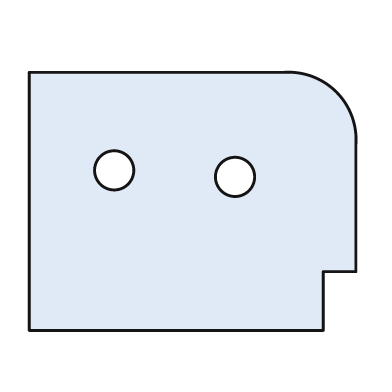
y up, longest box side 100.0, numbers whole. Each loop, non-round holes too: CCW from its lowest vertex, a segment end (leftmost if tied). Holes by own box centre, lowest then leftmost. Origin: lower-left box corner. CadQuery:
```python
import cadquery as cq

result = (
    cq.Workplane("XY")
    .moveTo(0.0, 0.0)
    .lineTo(90.0, 0.0)
    .lineTo(90.0, 18.0)
    .lineTo(100.0, 18.0)
    .lineTo(100.0, 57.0)
    .threePointArc((94.0, 73.0), (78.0, 79.0))
    .lineTo(0.0, 79.0)
    .close()
    .moveTo(63.0, 47.0)
    .circle(6.0)
    .moveTo(26.0, 49.0)
    .circle(6.0)
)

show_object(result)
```